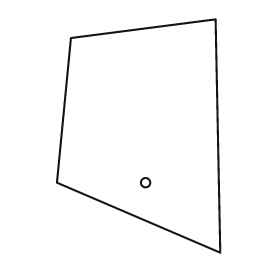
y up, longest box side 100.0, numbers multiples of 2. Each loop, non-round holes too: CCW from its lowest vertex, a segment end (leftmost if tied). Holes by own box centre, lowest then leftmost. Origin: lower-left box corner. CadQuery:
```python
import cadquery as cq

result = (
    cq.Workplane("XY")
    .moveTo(70.0, 0.0)
    .lineTo(68.0, 100.0)
    .lineTo(6.0, 92.0)
    .lineTo(0.0, 30.0)
    .close()
    .moveTo(38.0, 30.0)
    .circle(2.0)
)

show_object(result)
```